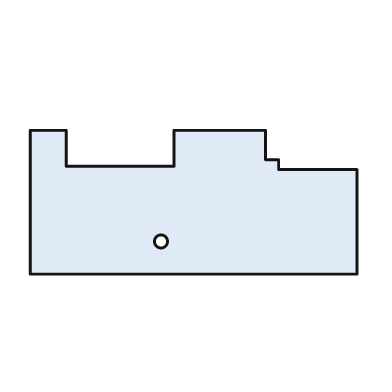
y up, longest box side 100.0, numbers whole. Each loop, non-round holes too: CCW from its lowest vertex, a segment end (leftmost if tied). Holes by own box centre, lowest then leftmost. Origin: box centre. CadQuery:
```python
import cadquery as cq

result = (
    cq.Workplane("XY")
    .moveTo(-50.0, -22.0)
    .lineTo(50.0, -22.0)
    .lineTo(50.0, 10.0)
    .lineTo(26.0, 10.0)
    .lineTo(26.0, 13.0)
    .lineTo(22.0, 13.0)
    .lineTo(22.0, 22.0)
    .lineTo(-6.0, 22.0)
    .lineTo(-6.0, 11.0)
    .lineTo(-39.0, 11.0)
    .lineTo(-39.0, 22.0)
    .lineTo(-50.0, 22.0)
    .close()
    .moveTo(-10.0, -12.0)
    .circle(2.0)
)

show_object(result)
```